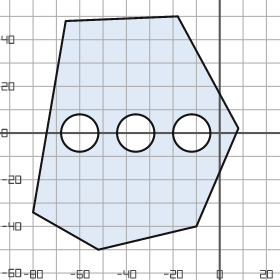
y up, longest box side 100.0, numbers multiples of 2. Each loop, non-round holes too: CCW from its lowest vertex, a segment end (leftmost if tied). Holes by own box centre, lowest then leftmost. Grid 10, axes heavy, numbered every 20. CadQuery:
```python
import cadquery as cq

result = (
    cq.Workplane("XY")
    .moveTo(-52.0, -50.0)
    .lineTo(-10.0, -40.0)
    .lineTo(8.0, 2.0)
    .lineTo(-18.0, 50.0)
    .lineTo(-66.0, 48.0)
    .lineTo(-80.0, -34.0)
    .close()
    .moveTo(-60.0, 0.0)
    .circle(8.0)
    .moveTo(-36.0, 0.0)
    .circle(8.0)
    .moveTo(-12.0, 0.0)
    .circle(8.0)
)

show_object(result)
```